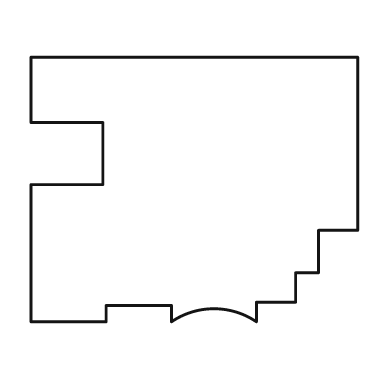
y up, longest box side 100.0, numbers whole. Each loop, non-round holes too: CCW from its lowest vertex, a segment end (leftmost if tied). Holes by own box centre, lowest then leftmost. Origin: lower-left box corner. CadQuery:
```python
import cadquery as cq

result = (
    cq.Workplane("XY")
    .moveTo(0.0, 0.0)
    .lineTo(23.0, 0.0)
    .lineTo(23.0, 5.0)
    .lineTo(43.0, 5.0)
    .lineTo(43.0, 0.0)
    .threePointArc((56.0, 4.0), (69.0, 0.0))
    .lineTo(69.0, 6.0)
    .lineTo(81.0, 6.0)
    .lineTo(81.0, 15.0)
    .lineTo(88.0, 15.0)
    .lineTo(88.0, 28.0)
    .lineTo(100.0, 28.0)
    .lineTo(100.0, 81.0)
    .lineTo(0.0, 81.0)
    .lineTo(0.0, 61.0)
    .lineTo(22.0, 61.0)
    .lineTo(22.0, 42.0)
    .lineTo(0.0, 42.0)
    .close()
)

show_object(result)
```